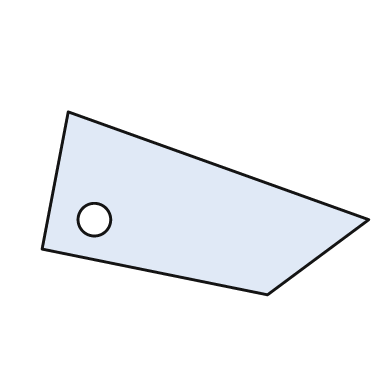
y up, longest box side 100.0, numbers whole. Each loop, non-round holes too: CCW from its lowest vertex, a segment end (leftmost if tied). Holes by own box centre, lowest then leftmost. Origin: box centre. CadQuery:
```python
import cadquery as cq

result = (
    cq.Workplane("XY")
    .moveTo(19.0, -28.0)
    .lineTo(50.0, -5.0)
    .lineTo(-42.0, 28.0)
    .lineTo(-50.0, -14.0)
    .close()
    .moveTo(-34.0, -5.0)
    .circle(5.0)
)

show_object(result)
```